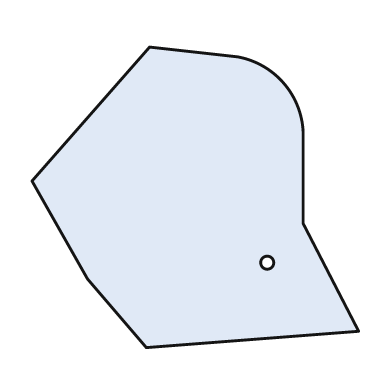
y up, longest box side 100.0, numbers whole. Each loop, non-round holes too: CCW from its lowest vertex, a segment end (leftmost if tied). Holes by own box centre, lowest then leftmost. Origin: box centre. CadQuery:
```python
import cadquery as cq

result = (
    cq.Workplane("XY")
    .moveTo(-15.0, -46.0)
    .lineTo(50.0, -41.0)
    .lineTo(33.0, -8.0)
    .lineTo(33.0, 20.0)
    .threePointArc((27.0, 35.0), (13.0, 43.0))
    .lineTo(-14.0, 46.0)
    .lineTo(-50.0, 5.0)
    .lineTo(-33.0, -25.0)
    .close()
    .moveTo(22.0, -20.0)
    .circle(2.0)
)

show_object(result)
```